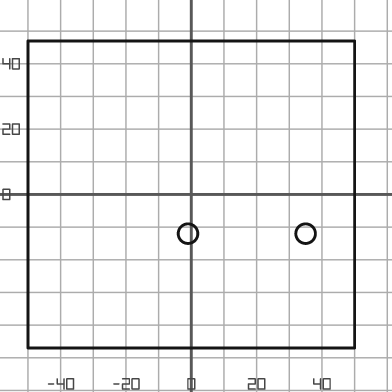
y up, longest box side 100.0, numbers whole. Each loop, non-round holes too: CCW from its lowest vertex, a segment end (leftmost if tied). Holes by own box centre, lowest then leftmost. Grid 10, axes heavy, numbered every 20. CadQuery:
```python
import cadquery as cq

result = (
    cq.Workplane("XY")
    .moveTo(-50.0, -47.0)
    .lineTo(50.0, -47.0)
    .lineTo(50.0, 47.0)
    .lineTo(-50.0, 47.0)
    .close()
    .moveTo(-1.0, -12.0)
    .circle(3.0)
    .moveTo(35.0, -12.0)
    .circle(3.0)
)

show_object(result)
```